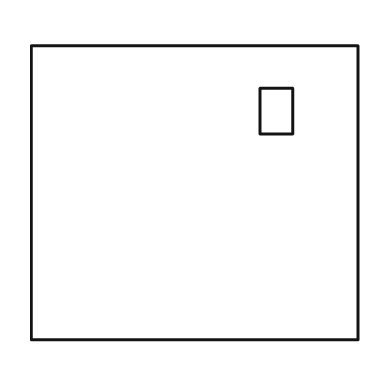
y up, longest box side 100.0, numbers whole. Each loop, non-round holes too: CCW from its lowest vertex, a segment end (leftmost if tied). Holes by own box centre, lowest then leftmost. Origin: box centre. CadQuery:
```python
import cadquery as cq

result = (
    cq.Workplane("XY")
    .moveTo(-50.0, -45.0)
    .lineTo(50.0, -45.0)
    .lineTo(50.0, 45.0)
    .lineTo(-50.0, 45.0)
    .close()
    .moveTo(20.0, 18.0)
    .lineTo(30.0, 18.0)
    .lineTo(30.0, 32.0)
    .lineTo(20.0, 32.0)
    .close()
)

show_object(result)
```